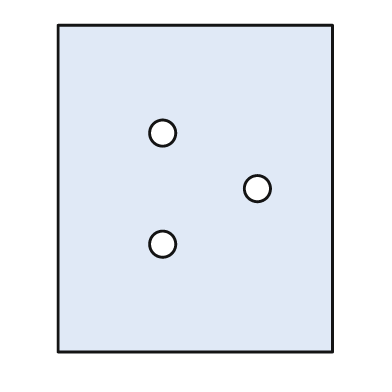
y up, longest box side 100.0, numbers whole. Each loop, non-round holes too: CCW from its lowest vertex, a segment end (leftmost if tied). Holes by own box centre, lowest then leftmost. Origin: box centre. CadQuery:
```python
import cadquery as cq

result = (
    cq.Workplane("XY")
    .moveTo(-42.0, -50.0)
    .lineTo(42.0, -50.0)
    .lineTo(42.0, 50.0)
    .lineTo(-42.0, 50.0)
    .close()
    .moveTo(-10.0, -17.0)
    .circle(4.0)
    .moveTo(19.0, 0.0)
    .circle(4.0)
    .moveTo(-10.0, 17.0)
    .circle(4.0)
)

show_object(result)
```